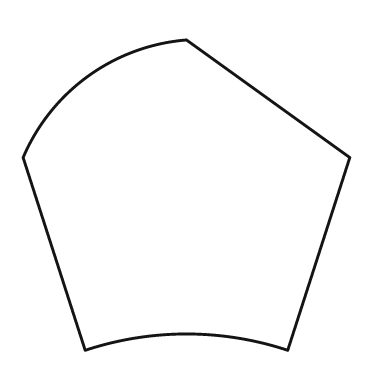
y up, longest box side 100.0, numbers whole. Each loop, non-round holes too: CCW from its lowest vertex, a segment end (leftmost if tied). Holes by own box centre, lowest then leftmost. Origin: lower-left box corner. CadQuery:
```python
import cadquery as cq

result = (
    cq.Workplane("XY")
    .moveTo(19.0, 0.0)
    .threePointArc((50.0, 5.0), (81.0, 0.0))
    .lineTo(100.0, 59.0)
    .lineTo(50.0, 95.0)
    .threePointArc((20.0, 84.0), (0.0, 59.0))
    .close()
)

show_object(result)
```